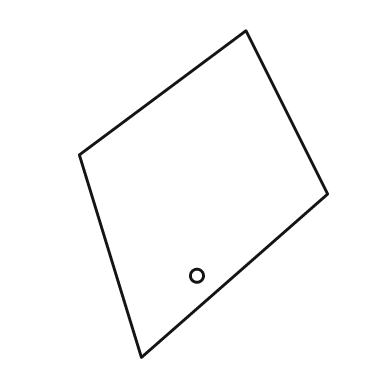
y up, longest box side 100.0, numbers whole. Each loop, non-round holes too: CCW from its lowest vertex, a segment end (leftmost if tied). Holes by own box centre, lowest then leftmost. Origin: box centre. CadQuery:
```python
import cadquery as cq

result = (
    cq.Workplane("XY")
    .moveTo(-19.0, -50.0)
    .lineTo(38.0, 0.0)
    .lineTo(13.0, 50.0)
    .lineTo(-38.0, 12.0)
    .close()
    .moveTo(-2.0, -25.0)
    .circle(2.0)
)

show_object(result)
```